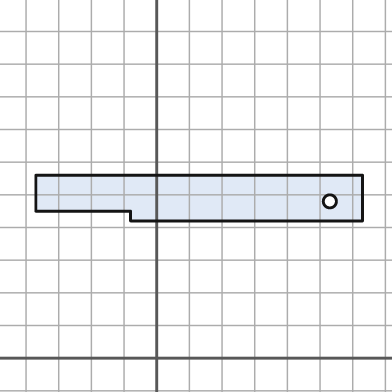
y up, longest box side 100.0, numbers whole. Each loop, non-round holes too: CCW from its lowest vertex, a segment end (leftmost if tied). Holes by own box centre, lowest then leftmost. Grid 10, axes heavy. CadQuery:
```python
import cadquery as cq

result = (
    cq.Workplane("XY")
    .moveTo(-8.0, 42.0)
    .lineTo(63.0, 42.0)
    .lineTo(63.0, 56.0)
    .lineTo(-37.0, 56.0)
    .lineTo(-37.0, 45.0)
    .lineTo(-8.0, 45.0)
    .close()
    .moveTo(53.0, 48.0)
    .circle(2.0)
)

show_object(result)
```